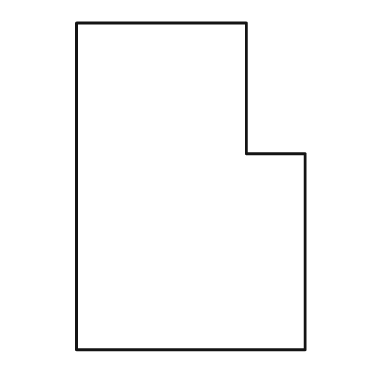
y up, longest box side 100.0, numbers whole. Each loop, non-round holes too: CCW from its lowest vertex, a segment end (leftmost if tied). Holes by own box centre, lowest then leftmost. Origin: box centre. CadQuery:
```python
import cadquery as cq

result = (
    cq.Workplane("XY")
    .moveTo(-35.0, -50.0)
    .lineTo(35.0, -50.0)
    .lineTo(35.0, 10.0)
    .lineTo(17.0, 10.0)
    .lineTo(17.0, 50.0)
    .lineTo(-35.0, 50.0)
    .close()
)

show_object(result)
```